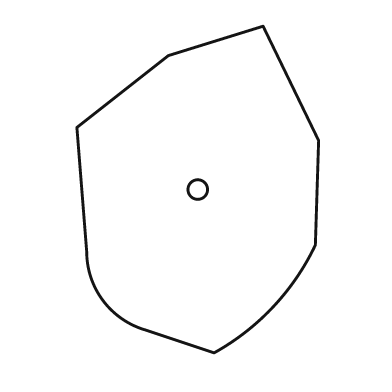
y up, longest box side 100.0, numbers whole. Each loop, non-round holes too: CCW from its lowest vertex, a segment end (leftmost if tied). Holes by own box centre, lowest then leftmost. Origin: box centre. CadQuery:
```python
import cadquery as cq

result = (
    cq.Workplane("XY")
    .moveTo(5.0, -50.0)
    .threePointArc((23.0, -36.0), (36.0, -17.0))
    .lineTo(37.0, 15.0)
    .lineTo(20.0, 50.0)
    .lineTo(-9.0, 41.0)
    .lineTo(-37.0, 19.0)
    .lineTo(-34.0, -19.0)
    .threePointArc((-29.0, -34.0), (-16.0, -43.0))
    .close()
    .moveTo(0.0, 0.0)
    .circle(3.0)
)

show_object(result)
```